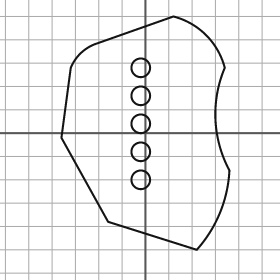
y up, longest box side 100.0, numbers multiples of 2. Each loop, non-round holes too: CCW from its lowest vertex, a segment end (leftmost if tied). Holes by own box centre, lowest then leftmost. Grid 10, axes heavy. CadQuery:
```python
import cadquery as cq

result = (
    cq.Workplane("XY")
    .moveTo(22.0, -50.0)
    .threePointArc((32.0, -34.0), (36.0, -16.0))
    .threePointArc((30.0, 6.0), (34.0, 28.0))
    .threePointArc((26.0, 42.0), (12.0, 50.0))
    .lineTo(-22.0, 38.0)
    .threePointArc((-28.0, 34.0), (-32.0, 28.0))
    .lineTo(-36.0, -2.0)
    .lineTo(-16.0, -38.0)
    .close()
    .moveTo(-2.0, -20.0)
    .circle(4.0)
    .moveTo(-2.0, -8.0)
    .circle(4.0)
    .moveTo(-2.0, 4.0)
    .circle(4.0)
    .moveTo(-2.0, 16.0)
    .circle(4.0)
    .moveTo(-2.0, 28.0)
    .circle(4.0)
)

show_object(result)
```